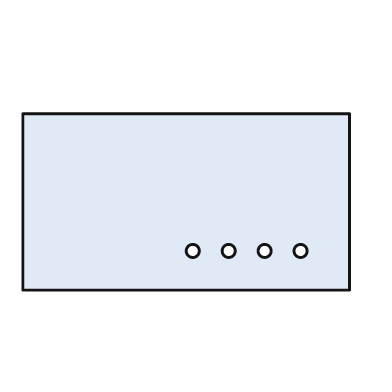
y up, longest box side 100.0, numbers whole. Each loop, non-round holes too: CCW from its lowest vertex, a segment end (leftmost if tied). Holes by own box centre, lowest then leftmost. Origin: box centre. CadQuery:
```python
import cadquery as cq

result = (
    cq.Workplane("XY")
    .moveTo(-50.0, -27.0)
    .lineTo(50.0, -27.0)
    .lineTo(50.0, 27.0)
    .lineTo(-50.0, 27.0)
    .close()
    .moveTo(2.0, -15.0)
    .circle(2.0)
    .moveTo(13.0, -15.0)
    .circle(2.0)
    .moveTo(24.0, -15.0)
    .circle(2.0)
    .moveTo(35.0, -15.0)
    .circle(2.0)
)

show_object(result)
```